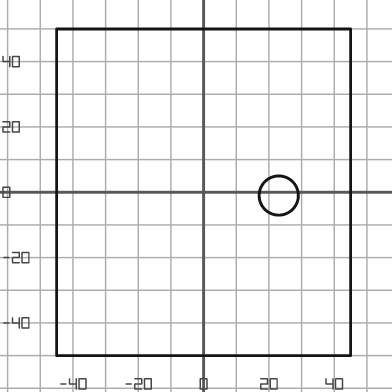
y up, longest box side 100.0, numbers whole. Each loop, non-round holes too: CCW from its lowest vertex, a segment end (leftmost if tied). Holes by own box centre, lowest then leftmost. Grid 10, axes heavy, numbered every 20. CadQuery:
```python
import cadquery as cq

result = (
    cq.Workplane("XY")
    .moveTo(-45.0, -50.0)
    .lineTo(45.0, -50.0)
    .lineTo(45.0, 50.0)
    .lineTo(-45.0, 50.0)
    .close()
    .moveTo(23.0, -1.0)
    .circle(6.0)
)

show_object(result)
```